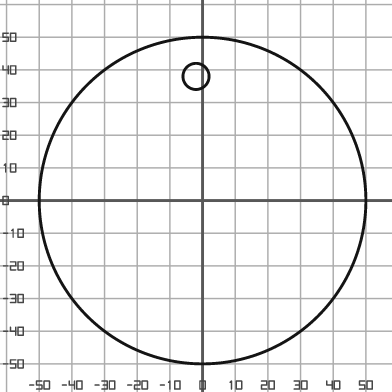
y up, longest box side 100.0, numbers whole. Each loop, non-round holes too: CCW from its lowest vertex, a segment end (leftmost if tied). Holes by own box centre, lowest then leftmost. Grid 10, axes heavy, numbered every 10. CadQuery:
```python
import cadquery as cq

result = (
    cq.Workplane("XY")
    .moveTo(0.0, 0.0)
    .circle(50.0)
    .moveTo(-2.0, 38.0)
    .circle(4.0)
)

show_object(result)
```